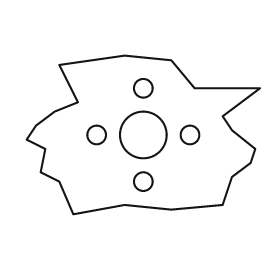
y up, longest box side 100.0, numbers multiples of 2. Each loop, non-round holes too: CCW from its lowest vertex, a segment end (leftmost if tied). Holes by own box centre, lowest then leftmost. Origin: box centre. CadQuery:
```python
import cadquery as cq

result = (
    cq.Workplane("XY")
    .moveTo(-30.0, -34.0)
    .lineTo(-8.0, -30.0)
    .lineTo(12.0, -32.0)
    .lineTo(34.0, -30.0)
    .lineTo(38.0, -18.0)
    .lineTo(46.0, -12.0)
    .lineTo(48.0, -6.0)
    .lineTo(38.0, 2.0)
    .lineTo(34.0, 8.0)
    .lineTo(50.0, 20.0)
    .lineTo(22.0, 20.0)
    .lineTo(12.0, 32.0)
    .lineTo(-8.0, 34.0)
    .lineTo(-36.0, 30.0)
    .lineTo(-28.0, 14.0)
    .lineTo(-38.0, 10.0)
    .lineTo(-46.0, 4.0)
    .lineTo(-50.0, -2.0)
    .lineTo(-42.0, -6.0)
    .lineTo(-44.0, -16.0)
    .lineTo(-36.0, -20.0)
    .close()
    .moveTo(0.0, -20.0)
    .circle(4.0)
    .moveTo(-20.0, 0.0)
    .circle(4.0)
    .moveTo(0.0, 0.0)
    .circle(10.0)
    .moveTo(20.0, 0.0)
    .circle(4.0)
    .moveTo(0.0, 20.0)
    .circle(4.0)
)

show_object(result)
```